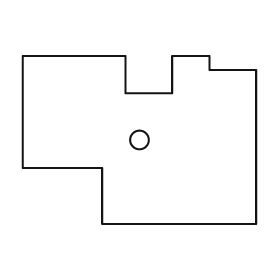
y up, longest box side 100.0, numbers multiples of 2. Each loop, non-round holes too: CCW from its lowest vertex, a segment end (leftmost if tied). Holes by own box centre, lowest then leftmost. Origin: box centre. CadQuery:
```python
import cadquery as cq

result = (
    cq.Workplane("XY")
    .moveTo(-16.0, -36.0)
    .lineTo(50.0, -36.0)
    .lineTo(50.0, 30.0)
    .lineTo(30.0, 30.0)
    .lineTo(30.0, 36.0)
    .lineTo(14.0, 36.0)
    .lineTo(14.0, 20.0)
    .lineTo(-6.0, 20.0)
    .lineTo(-6.0, 36.0)
    .lineTo(-50.0, 36.0)
    .lineTo(-50.0, -12.0)
    .lineTo(-16.0, -12.0)
    .close()
    .moveTo(0.0, 0.0)
    .circle(4.0)
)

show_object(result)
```